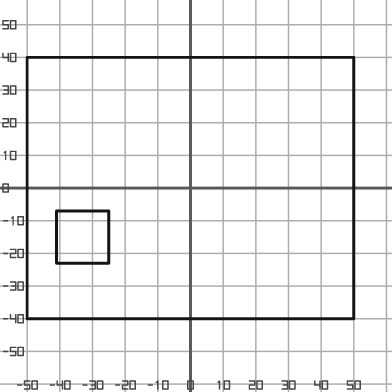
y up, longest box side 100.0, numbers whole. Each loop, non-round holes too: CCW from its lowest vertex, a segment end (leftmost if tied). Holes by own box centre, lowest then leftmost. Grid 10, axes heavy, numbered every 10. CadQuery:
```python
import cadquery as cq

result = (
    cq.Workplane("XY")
    .moveTo(-50.0, -40.0)
    .lineTo(50.0, -40.0)
    .lineTo(50.0, 40.0)
    .lineTo(-50.0, 40.0)
    .close()
    .moveTo(-41.0, -23.0)
    .lineTo(-25.0, -23.0)
    .lineTo(-25.0, -7.0)
    .lineTo(-41.0, -7.0)
    .close()
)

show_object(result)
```